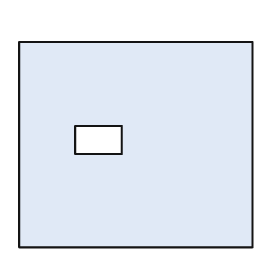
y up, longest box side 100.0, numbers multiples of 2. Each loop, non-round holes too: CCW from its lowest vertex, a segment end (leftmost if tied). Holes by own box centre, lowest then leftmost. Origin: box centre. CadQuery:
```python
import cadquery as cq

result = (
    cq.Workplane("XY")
    .moveTo(-50.0, -44.0)
    .lineTo(50.0, -44.0)
    .lineTo(50.0, 44.0)
    .lineTo(-50.0, 44.0)
    .close()
    .moveTo(-26.0, -4.0)
    .lineTo(-6.0, -4.0)
    .lineTo(-6.0, 8.0)
    .lineTo(-26.0, 8.0)
    .close()
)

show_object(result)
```